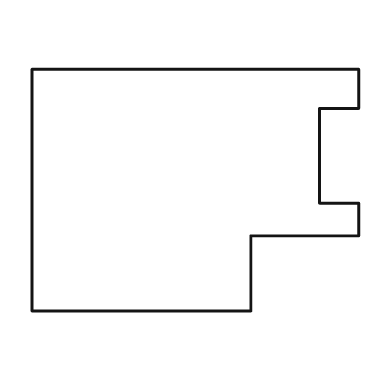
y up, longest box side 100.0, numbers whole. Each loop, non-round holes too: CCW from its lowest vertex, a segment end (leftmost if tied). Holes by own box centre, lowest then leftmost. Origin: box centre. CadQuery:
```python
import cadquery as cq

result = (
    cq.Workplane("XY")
    .moveTo(-50.0, -37.0)
    .lineTo(17.0, -37.0)
    .lineTo(17.0, -14.0)
    .lineTo(50.0, -14.0)
    .lineTo(50.0, -4.0)
    .lineTo(38.0, -4.0)
    .lineTo(38.0, 25.0)
    .lineTo(50.0, 25.0)
    .lineTo(50.0, 37.0)
    .lineTo(-50.0, 37.0)
    .close()
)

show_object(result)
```